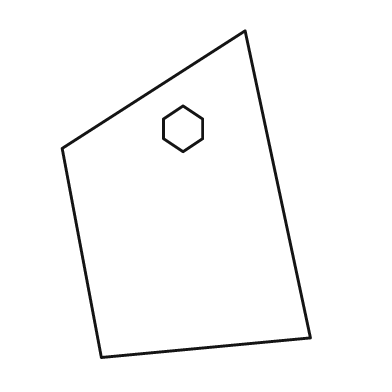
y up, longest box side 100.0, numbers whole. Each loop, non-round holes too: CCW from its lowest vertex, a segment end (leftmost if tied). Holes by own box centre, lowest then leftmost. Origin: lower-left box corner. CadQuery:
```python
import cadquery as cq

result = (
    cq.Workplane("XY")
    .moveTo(12.0, 0.0)
    .lineTo(76.0, 6.0)
    .lineTo(56.0, 100.0)
    .lineTo(0.0, 64.0)
    .close()
    .moveTo(37.0, 63.0)
    .lineTo(43.0, 67.0)
    .lineTo(43.0, 73.0)
    .lineTo(37.0, 77.0)
    .lineTo(31.0, 73.0)
    .lineTo(31.0, 67.0)
    .close()
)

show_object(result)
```